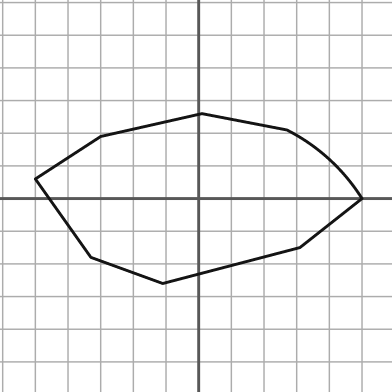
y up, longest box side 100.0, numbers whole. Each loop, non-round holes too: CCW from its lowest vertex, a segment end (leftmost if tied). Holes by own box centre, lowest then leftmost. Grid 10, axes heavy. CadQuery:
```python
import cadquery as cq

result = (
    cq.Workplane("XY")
    .moveTo(-11.0, -26.0)
    .lineTo(31.0, -15.0)
    .lineTo(50.0, 0.0)
    .threePointArc((40.0, 12.0), (27.0, 21.0))
    .lineTo(1.0, 26.0)
    .lineTo(-30.0, 19.0)
    .lineTo(-50.0, 6.0)
    .lineTo(-33.0, -18.0)
    .close()
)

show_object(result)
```